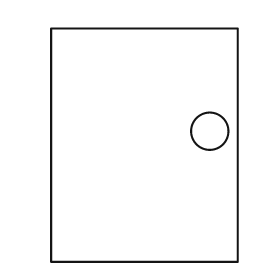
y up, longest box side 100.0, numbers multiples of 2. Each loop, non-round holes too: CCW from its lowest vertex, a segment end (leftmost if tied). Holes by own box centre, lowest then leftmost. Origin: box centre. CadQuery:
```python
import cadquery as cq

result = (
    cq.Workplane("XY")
    .moveTo(-40.0, -50.0)
    .lineTo(40.0, -50.0)
    .lineTo(40.0, 50.0)
    .lineTo(-40.0, 50.0)
    .close()
    .moveTo(28.0, 6.0)
    .circle(8.0)
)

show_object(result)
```